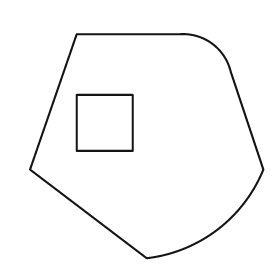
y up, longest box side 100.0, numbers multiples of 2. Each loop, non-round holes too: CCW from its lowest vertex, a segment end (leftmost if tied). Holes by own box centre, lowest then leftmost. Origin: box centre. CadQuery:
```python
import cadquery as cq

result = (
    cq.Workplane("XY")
    .moveTo(0.0, -48.0)
    .threePointArc((30.0, -36.0), (50.0, -10.0))
    .lineTo(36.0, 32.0)
    .threePointArc((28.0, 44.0), (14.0, 48.0))
    .lineTo(-30.0, 48.0)
    .lineTo(-50.0, -10.0)
    .close()
    .moveTo(-30.0, -2.0)
    .lineTo(-6.0, -2.0)
    .lineTo(-6.0, 22.0)
    .lineTo(-30.0, 22.0)
    .close()
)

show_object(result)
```